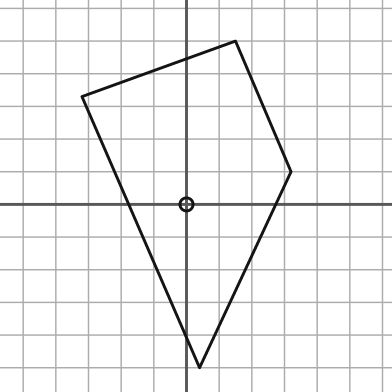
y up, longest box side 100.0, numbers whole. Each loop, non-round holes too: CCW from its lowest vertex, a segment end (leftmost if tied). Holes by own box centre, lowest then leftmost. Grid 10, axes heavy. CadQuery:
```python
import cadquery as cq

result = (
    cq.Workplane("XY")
    .moveTo(4.0, -50.0)
    .lineTo(32.0, 10.0)
    .lineTo(15.0, 50.0)
    .lineTo(-32.0, 33.0)
    .close()
    .moveTo(0.0, 0.0)
    .circle(2.0)
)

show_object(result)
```